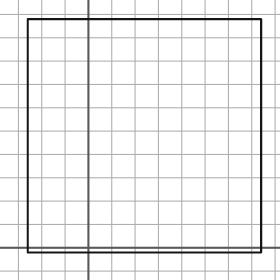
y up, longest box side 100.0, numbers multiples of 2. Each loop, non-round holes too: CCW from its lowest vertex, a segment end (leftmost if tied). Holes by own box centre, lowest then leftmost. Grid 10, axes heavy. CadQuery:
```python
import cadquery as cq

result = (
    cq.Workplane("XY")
    .moveTo(-26.0, -2.0)
    .lineTo(74.0, -2.0)
    .lineTo(74.0, 98.0)
    .lineTo(-26.0, 98.0)
    .close()
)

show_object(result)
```